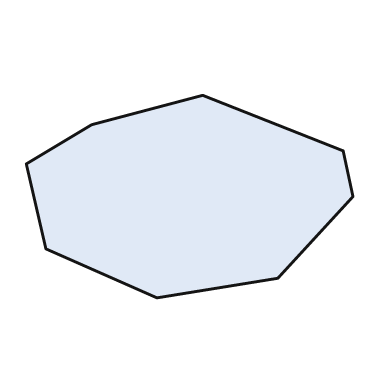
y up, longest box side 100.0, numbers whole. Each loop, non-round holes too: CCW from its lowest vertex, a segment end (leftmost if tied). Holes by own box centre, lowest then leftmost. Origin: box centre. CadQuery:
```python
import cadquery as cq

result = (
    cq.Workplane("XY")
    .moveTo(-10.0, -31.0)
    .lineTo(27.0, -25.0)
    .lineTo(50.0, 0.0)
    .lineTo(47.0, 14.0)
    .lineTo(4.0, 31.0)
    .lineTo(-30.0, 22.0)
    .lineTo(-50.0, 10.0)
    .lineTo(-44.0, -16.0)
    .close()
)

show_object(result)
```